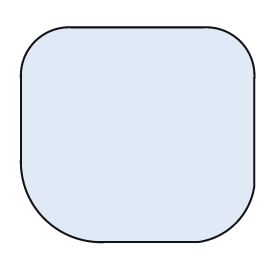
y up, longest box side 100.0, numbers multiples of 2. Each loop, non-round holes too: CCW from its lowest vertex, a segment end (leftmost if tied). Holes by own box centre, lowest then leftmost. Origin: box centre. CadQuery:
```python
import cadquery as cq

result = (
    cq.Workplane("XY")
    .moveTo(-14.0, -46.0)
    .lineTo(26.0, -46.0)
    .threePointArc((42.0, -38.0), (50.0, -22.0))
    .lineTo(50.0, 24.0)
    .threePointArc((44.0, 40.0), (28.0, 46.0))
    .lineTo(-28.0, 46.0)
    .threePointArc((-44.0, 40.0), (-50.0, 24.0))
    .lineTo(-50.0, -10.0)
    .threePointArc((-40.0, -36.0), (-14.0, -46.0))
    .close()
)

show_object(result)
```